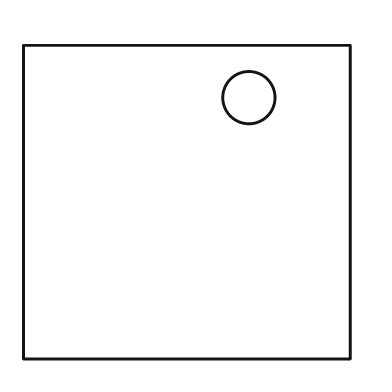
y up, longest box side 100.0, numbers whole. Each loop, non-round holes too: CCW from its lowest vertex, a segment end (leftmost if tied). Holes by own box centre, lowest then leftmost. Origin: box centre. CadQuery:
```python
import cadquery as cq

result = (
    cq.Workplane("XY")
    .moveTo(-50.0, -48.0)
    .lineTo(50.0, -48.0)
    .lineTo(50.0, 48.0)
    .lineTo(-50.0, 48.0)
    .close()
    .moveTo(19.0, 32.0)
    .circle(8.0)
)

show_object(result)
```